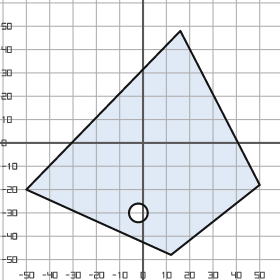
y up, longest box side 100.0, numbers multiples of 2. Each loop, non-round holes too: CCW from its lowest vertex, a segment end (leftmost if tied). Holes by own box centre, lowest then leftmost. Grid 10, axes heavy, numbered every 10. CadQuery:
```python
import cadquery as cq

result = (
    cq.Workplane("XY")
    .moveTo(12.0, -48.0)
    .lineTo(50.0, -18.0)
    .lineTo(16.0, 48.0)
    .lineTo(-50.0, -20.0)
    .close()
    .moveTo(-2.0, -30.0)
    .circle(4.0)
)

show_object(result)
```